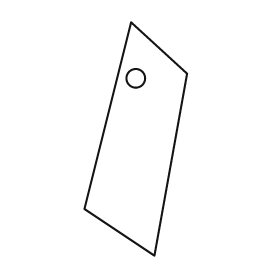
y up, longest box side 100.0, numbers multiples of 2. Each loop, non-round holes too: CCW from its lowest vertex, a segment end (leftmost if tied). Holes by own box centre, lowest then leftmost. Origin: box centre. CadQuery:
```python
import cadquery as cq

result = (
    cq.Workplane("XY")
    .moveTo(8.0, -50.0)
    .lineTo(22.0, 28.0)
    .lineTo(-2.0, 50.0)
    .lineTo(-22.0, -30.0)
    .close()
    .moveTo(0.0, 26.0)
    .circle(4.0)
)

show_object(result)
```